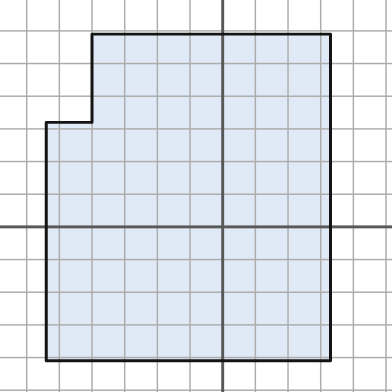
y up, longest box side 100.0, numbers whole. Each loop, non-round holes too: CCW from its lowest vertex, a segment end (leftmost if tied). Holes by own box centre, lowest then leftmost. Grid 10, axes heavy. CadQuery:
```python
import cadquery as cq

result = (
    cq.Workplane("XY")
    .moveTo(-54.0, -41.0)
    .lineTo(33.0, -41.0)
    .lineTo(33.0, 59.0)
    .lineTo(-40.0, 59.0)
    .lineTo(-40.0, 32.0)
    .lineTo(-54.0, 32.0)
    .close()
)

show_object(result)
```